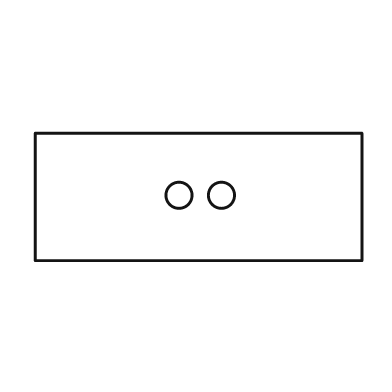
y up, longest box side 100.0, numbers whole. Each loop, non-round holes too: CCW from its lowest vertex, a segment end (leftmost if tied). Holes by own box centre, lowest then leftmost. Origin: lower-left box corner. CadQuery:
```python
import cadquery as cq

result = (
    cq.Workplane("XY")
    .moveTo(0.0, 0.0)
    .lineTo(100.0, 0.0)
    .lineTo(100.0, 39.0)
    .lineTo(0.0, 39.0)
    .close()
    .moveTo(44.0, 20.0)
    .circle(4.0)
    .moveTo(57.0, 20.0)
    .circle(4.0)
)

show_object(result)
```